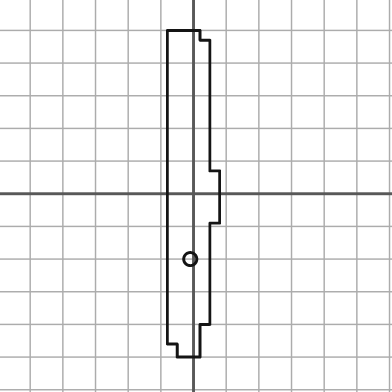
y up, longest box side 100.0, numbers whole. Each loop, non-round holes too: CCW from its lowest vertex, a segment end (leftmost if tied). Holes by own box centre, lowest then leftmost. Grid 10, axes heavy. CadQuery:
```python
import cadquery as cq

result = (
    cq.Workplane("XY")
    .moveTo(-5.0, -50.0)
    .lineTo(2.0, -50.0)
    .lineTo(2.0, -40.0)
    .lineTo(5.0, -40.0)
    .lineTo(5.0, -9.0)
    .lineTo(8.0, -9.0)
    .lineTo(8.0, 7.0)
    .lineTo(5.0, 7.0)
    .lineTo(5.0, 47.0)
    .lineTo(2.0, 47.0)
    .lineTo(2.0, 50.0)
    .lineTo(-8.0, 50.0)
    .lineTo(-8.0, -46.0)
    .lineTo(-5.0, -46.0)
    .close()
    .moveTo(-1.0, -20.0)
    .circle(2.0)
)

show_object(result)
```